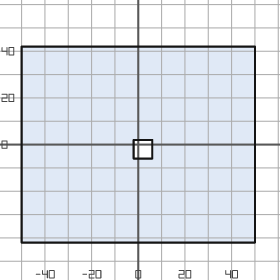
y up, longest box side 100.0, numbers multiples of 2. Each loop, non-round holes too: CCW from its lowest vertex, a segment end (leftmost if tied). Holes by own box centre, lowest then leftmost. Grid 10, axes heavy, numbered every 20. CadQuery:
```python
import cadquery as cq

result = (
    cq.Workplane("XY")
    .moveTo(-50.0, -42.0)
    .lineTo(50.0, -42.0)
    .lineTo(50.0, 42.0)
    .lineTo(-50.0, 42.0)
    .close()
    .moveTo(-2.0, -6.0)
    .lineTo(6.0, -6.0)
    .lineTo(6.0, 2.0)
    .lineTo(-2.0, 2.0)
    .close()
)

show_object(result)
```